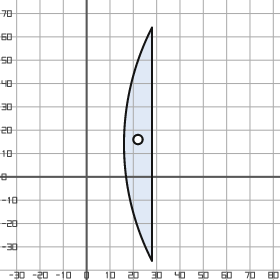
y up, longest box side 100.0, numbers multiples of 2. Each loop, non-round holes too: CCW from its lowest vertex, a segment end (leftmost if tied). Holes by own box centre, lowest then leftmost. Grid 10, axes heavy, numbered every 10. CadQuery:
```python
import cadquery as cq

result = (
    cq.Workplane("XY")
    .moveTo(28.0, -36.0)
    .lineTo(28.0, 64.0)
    .threePointArc((16.0, 14.0), (28.0, -36.0))
    .close()
    .moveTo(22.0, 16.0)
    .circle(2.0)
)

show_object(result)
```